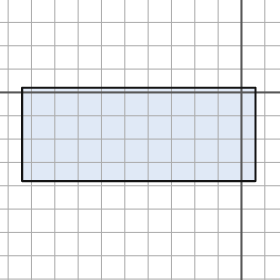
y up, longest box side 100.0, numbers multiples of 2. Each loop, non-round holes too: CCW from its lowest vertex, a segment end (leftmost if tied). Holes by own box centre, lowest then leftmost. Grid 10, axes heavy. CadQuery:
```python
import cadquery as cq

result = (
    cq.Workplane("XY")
    .moveTo(-94.0, -38.0)
    .lineTo(6.0, -38.0)
    .lineTo(6.0, 2.0)
    .lineTo(-94.0, 2.0)
    .close()
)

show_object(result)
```